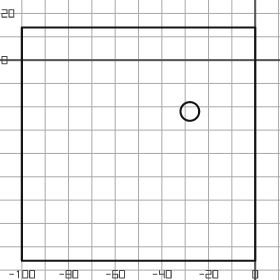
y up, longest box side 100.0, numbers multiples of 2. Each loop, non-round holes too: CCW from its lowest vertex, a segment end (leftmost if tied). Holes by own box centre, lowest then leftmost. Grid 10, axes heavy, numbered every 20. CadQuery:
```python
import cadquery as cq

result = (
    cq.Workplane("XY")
    .moveTo(-100.0, -86.0)
    .lineTo(0.0, -86.0)
    .lineTo(0.0, 14.0)
    .lineTo(-100.0, 14.0)
    .close()
    .moveTo(-28.0, -22.0)
    .circle(4.0)
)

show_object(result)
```